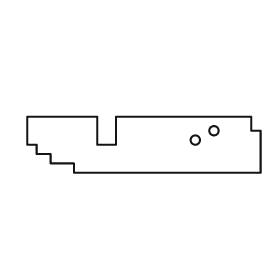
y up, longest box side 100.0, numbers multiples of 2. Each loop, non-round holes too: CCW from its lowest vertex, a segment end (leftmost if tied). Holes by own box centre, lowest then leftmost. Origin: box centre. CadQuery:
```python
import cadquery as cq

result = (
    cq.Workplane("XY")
    .moveTo(-30.0, -12.0)
    .lineTo(50.0, -12.0)
    .lineTo(50.0, 6.0)
    .lineTo(46.0, 6.0)
    .lineTo(46.0, 12.0)
    .lineTo(-12.0, 12.0)
    .lineTo(-12.0, 0.0)
    .lineTo(-20.0, 0.0)
    .lineTo(-20.0, 12.0)
    .lineTo(-50.0, 12.0)
    .lineTo(-50.0, 0.0)
    .lineTo(-46.0, 0.0)
    .lineTo(-46.0, -4.0)
    .lineTo(-40.0, -4.0)
    .lineTo(-40.0, -8.0)
    .lineTo(-30.0, -8.0)
    .close()
    .moveTo(22.0, 2.0)
    .circle(2.0)
    .moveTo(30.0, 6.0)
    .circle(2.0)
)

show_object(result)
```